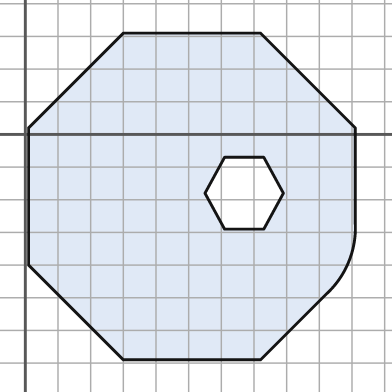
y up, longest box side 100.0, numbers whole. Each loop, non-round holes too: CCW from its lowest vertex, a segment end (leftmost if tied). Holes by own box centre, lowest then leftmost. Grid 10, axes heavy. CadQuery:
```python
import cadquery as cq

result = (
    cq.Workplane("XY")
    .moveTo(30.0, -69.0)
    .lineTo(72.0, -69.0)
    .lineTo(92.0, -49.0)
    .threePointArc((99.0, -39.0), (101.0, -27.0))
    .lineTo(101.0, 2.0)
    .lineTo(72.0, 31.0)
    .lineTo(30.0, 31.0)
    .lineTo(1.0, 2.0)
    .lineTo(1.0, -40.0)
    .close()
    .moveTo(61.0, -29.0)
    .lineTo(73.0, -29.0)
    .lineTo(79.0, -18.0)
    .lineTo(73.0, -7.0)
    .lineTo(61.0, -7.0)
    .lineTo(55.0, -18.0)
    .close()
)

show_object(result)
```